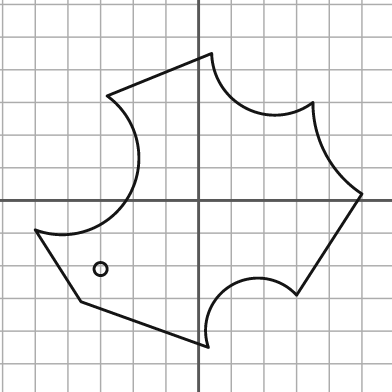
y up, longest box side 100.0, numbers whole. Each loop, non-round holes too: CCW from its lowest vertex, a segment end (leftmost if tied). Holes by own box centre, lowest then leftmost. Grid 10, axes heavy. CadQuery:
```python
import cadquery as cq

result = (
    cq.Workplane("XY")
    .moveTo(3.0, -45.0)
    .threePointArc((10.0, -26.0), (30.0, -29.0))
    .lineTo(50.0, 2.0)
    .threePointArc((39.0, 14.0), (35.0, 30.0))
    .threePointArc((15.0, 28.0), (4.0, 45.0))
    .lineTo(-28.0, 32.0)
    .threePointArc((-21.0, 2.0), (-50.0, -9.0))
    .lineTo(-36.0, -31.0)
    .close()
    .moveTo(-30.0, -21.0)
    .circle(2.0)
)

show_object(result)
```